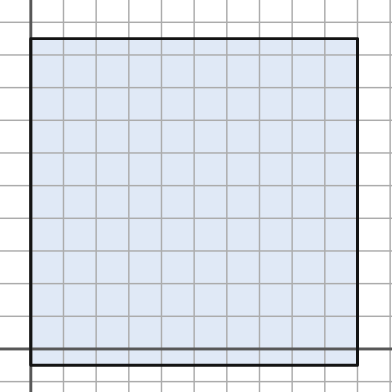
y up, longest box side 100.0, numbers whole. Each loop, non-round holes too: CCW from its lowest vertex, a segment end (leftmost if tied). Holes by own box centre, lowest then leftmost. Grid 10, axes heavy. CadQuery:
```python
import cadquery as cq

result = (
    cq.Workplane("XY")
    .moveTo(0.0, -5.0)
    .lineTo(100.0, -5.0)
    .lineTo(100.0, 95.0)
    .lineTo(0.0, 95.0)
    .close()
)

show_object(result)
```